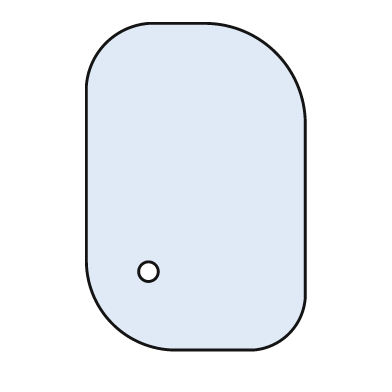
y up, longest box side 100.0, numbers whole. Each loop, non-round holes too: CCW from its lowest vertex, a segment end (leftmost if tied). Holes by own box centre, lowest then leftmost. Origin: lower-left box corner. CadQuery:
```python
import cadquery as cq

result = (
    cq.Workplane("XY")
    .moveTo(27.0, 0.0)
    .lineTo(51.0, 0.0)
    .threePointArc((62.0, 5.0), (67.0, 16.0))
    .lineTo(67.0, 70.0)
    .threePointArc((58.0, 91.0), (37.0, 100.0))
    .lineTo(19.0, 100.0)
    .threePointArc((6.0, 94.0), (0.0, 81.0))
    .lineTo(0.0, 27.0)
    .threePointArc((8.0, 8.0), (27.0, 0.0))
    .close()
    .moveTo(19.0, 24.0)
    .circle(3.0)
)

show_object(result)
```